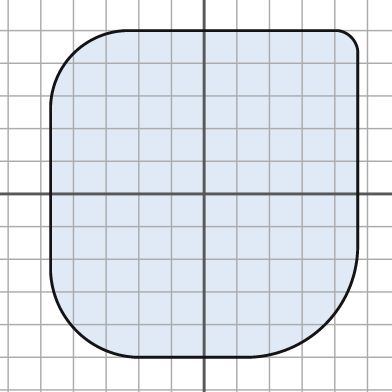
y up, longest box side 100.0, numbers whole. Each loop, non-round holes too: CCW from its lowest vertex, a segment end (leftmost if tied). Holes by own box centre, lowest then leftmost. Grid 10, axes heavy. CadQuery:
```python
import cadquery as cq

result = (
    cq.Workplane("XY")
    .moveTo(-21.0, -50.0)
    .lineTo(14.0, -50.0)
    .threePointArc((37.0, -40.0), (47.0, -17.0))
    .lineTo(47.0, 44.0)
    .threePointArc((45.0, 48.0), (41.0, 50.0))
    .lineTo(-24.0, 50.0)
    .threePointArc((-40.0, 43.0), (-47.0, 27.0))
    .lineTo(-47.0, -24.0)
    .threePointArc((-39.0, -42.0), (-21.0, -50.0))
    .close()
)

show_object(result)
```